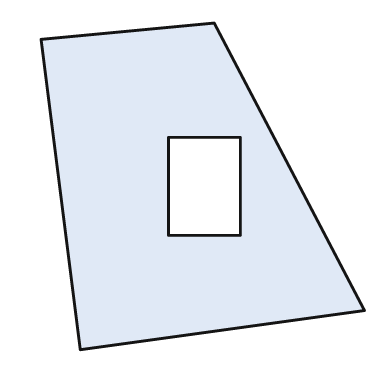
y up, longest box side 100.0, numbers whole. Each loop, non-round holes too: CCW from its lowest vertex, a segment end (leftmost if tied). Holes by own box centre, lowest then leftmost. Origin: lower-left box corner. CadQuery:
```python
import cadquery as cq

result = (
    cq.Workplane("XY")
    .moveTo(12.0, 0.0)
    .lineTo(99.0, 12.0)
    .lineTo(53.0, 100.0)
    .lineTo(0.0, 95.0)
    .close()
    .moveTo(39.0, 35.0)
    .lineTo(61.0, 35.0)
    .lineTo(61.0, 65.0)
    .lineTo(39.0, 65.0)
    .close()
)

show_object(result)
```